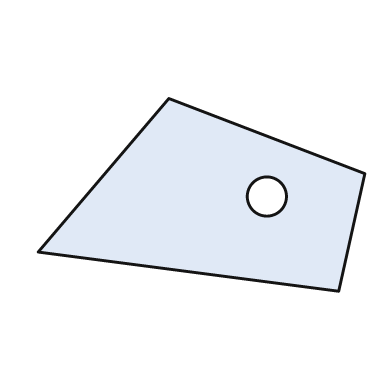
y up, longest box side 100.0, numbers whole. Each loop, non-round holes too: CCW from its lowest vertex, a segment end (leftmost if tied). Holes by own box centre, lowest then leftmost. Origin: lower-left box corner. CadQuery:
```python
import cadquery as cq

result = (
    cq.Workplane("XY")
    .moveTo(92.0, 0.0)
    .lineTo(100.0, 36.0)
    .lineTo(40.0, 59.0)
    .lineTo(0.0, 12.0)
    .close()
    .moveTo(70.0, 29.0)
    .circle(6.0)
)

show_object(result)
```